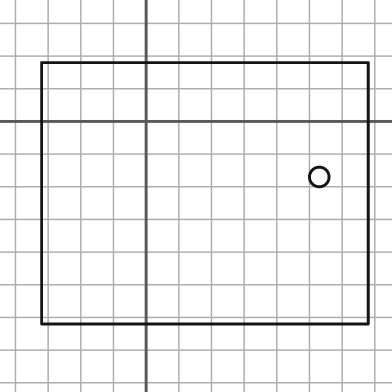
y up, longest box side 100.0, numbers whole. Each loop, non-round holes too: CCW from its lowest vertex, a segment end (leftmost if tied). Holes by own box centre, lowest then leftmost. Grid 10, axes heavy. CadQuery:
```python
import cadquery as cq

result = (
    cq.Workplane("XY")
    .moveTo(-32.0, -62.0)
    .lineTo(68.0, -62.0)
    .lineTo(68.0, 18.0)
    .lineTo(-32.0, 18.0)
    .close()
    .moveTo(53.0, -17.0)
    .circle(3.0)
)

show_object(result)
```